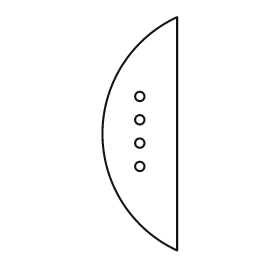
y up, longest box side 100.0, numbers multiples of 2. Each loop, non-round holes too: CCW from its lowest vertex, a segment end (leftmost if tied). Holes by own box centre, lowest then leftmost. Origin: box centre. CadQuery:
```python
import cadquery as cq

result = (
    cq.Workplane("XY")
    .moveTo(16.0, -50.0)
    .lineTo(16.0, 50.0)
    .threePointArc((-16.0, 0.0), (16.0, -50.0))
    .close()
    .moveTo(0.0, -14.0)
    .circle(2.0)
    .moveTo(0.0, -4.0)
    .circle(2.0)
    .moveTo(0.0, 6.0)
    .circle(2.0)
    .moveTo(0.0, 16.0)
    .circle(2.0)
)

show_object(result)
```